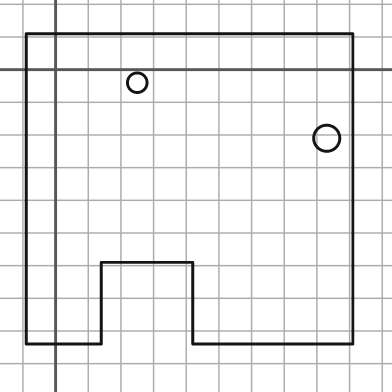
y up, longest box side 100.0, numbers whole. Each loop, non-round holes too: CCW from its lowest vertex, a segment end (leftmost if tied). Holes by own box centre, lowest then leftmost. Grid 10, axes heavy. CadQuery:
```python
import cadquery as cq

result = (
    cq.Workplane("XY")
    .moveTo(-9.0, -84.0)
    .lineTo(14.0, -84.0)
    .lineTo(14.0, -59.0)
    .lineTo(42.0, -59.0)
    .lineTo(42.0, -84.0)
    .lineTo(91.0, -84.0)
    .lineTo(91.0, 11.0)
    .lineTo(-9.0, 11.0)
    .close()
    .moveTo(83.0, -21.0)
    .circle(4.0)
    .moveTo(25.0, -4.0)
    .circle(3.0)
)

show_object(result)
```